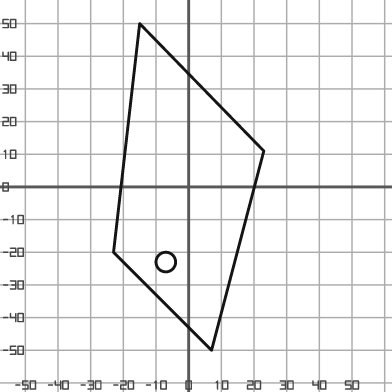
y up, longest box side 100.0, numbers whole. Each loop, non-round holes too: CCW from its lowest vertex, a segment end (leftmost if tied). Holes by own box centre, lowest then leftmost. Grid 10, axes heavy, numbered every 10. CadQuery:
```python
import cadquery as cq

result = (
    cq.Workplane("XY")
    .moveTo(7.0, -50.0)
    .lineTo(23.0, 11.0)
    .lineTo(-15.0, 50.0)
    .lineTo(-23.0, -20.0)
    .close()
    .moveTo(-7.0, -23.0)
    .circle(3.0)
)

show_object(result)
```